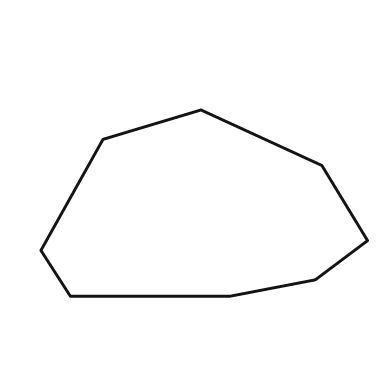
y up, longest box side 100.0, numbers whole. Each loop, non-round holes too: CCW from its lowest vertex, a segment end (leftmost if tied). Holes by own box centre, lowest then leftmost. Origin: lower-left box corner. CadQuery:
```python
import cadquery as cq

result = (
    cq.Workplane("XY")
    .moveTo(9.0, 0.0)
    .lineTo(58.0, 0.0)
    .lineTo(84.0, 5.0)
    .lineTo(100.0, 17.0)
    .lineTo(86.0, 40.0)
    .lineTo(49.0, 57.0)
    .lineTo(19.0, 48.0)
    .lineTo(0.0, 14.0)
    .close()
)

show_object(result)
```